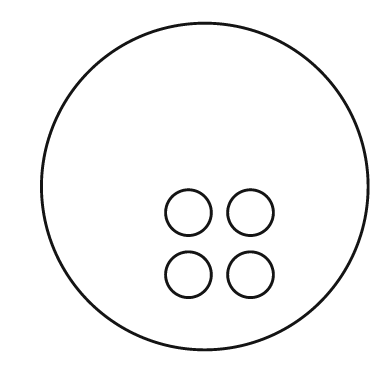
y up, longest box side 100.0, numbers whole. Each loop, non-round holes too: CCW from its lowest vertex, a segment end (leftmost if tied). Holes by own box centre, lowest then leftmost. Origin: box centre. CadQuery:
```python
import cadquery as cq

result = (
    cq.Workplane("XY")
    .moveTo(0.0, 0.0)
    .circle(50.0)
    .moveTo(-5.0, -27.0)
    .circle(7.0)
    .moveTo(14.0, -27.0)
    .circle(7.0)
    .moveTo(-5.0, -8.0)
    .circle(7.0)
    .moveTo(14.0, -8.0)
    .circle(7.0)
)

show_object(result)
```